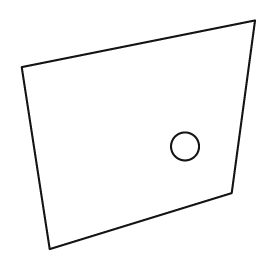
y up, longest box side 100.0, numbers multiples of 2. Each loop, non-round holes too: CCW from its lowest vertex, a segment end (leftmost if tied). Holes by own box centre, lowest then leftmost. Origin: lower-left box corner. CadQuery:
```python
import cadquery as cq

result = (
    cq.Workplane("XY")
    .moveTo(12.0, 0.0)
    .lineTo(90.0, 24.0)
    .lineTo(100.0, 98.0)
    .lineTo(0.0, 78.0)
    .close()
    .moveTo(70.0, 44.0)
    .circle(6.0)
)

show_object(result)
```